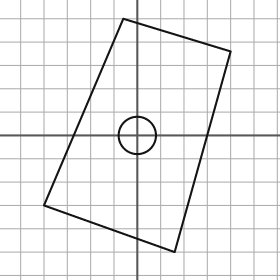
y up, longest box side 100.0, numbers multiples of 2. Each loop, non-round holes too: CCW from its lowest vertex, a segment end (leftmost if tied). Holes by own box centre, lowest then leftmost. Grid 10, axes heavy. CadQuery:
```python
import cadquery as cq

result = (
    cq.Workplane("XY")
    .moveTo(16.0, -50.0)
    .lineTo(40.0, 36.0)
    .lineTo(-6.0, 50.0)
    .lineTo(-40.0, -30.0)
    .close()
    .moveTo(0.0, 0.0)
    .circle(8.0)
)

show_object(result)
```